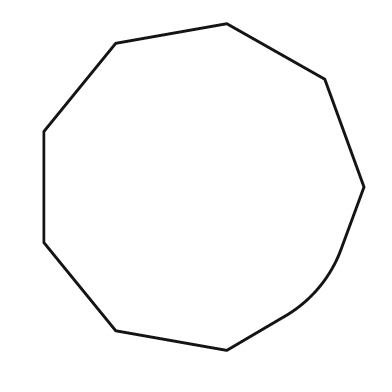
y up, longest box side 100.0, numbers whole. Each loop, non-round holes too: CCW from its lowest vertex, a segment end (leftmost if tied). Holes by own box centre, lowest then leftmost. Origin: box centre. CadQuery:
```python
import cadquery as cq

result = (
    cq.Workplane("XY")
    .moveTo(7.0, -50.0)
    .lineTo(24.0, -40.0)
    .threePointArc((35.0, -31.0), (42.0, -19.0))
    .lineTo(49.0, 0.0)
    .lineTo(37.0, 33.0)
    .lineTo(7.0, 50.0)
    .lineTo(-27.0, 44.0)
    .lineTo(-49.0, 17.0)
    .lineTo(-49.0, -17.0)
    .lineTo(-27.0, -44.0)
    .close()
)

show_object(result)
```